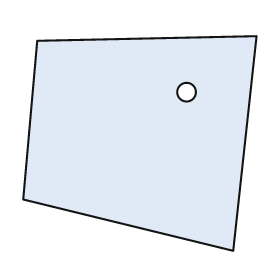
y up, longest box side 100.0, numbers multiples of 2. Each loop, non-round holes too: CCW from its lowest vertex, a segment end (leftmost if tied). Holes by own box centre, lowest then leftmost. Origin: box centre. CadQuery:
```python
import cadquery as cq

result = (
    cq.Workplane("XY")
    .moveTo(40.0, -46.0)
    .lineTo(50.0, 46.0)
    .lineTo(-44.0, 44.0)
    .lineTo(-50.0, -24.0)
    .close()
    .moveTo(20.0, 22.0)
    .circle(4.0)
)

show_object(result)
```